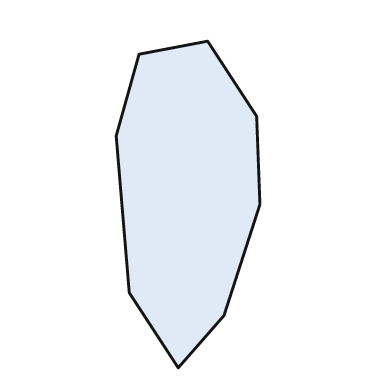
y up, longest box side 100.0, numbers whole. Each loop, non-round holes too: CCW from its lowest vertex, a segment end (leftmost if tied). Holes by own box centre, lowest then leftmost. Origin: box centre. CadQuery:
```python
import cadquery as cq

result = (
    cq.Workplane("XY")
    .moveTo(-3.0, -50.0)
    .lineTo(11.0, -34.0)
    .lineTo(22.0, 0.0)
    .lineTo(21.0, 27.0)
    .lineTo(6.0, 50.0)
    .lineTo(-15.0, 46.0)
    .lineTo(-22.0, 21.0)
    .lineTo(-18.0, -27.0)
    .close()
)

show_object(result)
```